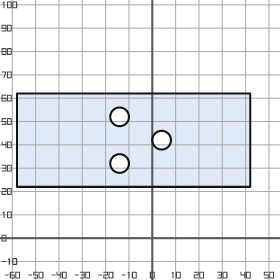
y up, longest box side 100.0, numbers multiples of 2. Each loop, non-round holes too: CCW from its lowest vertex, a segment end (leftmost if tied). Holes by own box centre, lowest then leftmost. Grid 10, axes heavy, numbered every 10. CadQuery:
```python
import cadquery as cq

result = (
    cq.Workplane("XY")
    .moveTo(-58.0, 22.0)
    .lineTo(42.0, 22.0)
    .lineTo(42.0, 62.0)
    .lineTo(-58.0, 62.0)
    .close()
    .moveTo(-14.0, 32.0)
    .circle(4.0)
    .moveTo(4.0, 42.0)
    .circle(4.0)
    .moveTo(-14.0, 52.0)
    .circle(4.0)
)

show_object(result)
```